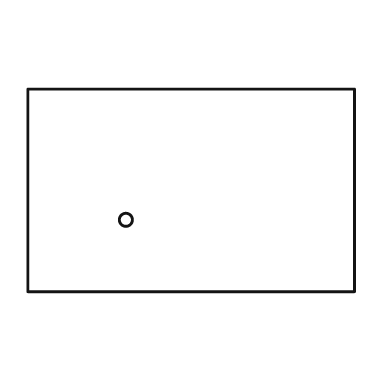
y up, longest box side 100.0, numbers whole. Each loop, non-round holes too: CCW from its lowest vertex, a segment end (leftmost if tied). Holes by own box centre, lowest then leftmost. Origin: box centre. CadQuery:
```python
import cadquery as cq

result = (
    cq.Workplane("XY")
    .moveTo(-50.0, -31.0)
    .lineTo(50.0, -31.0)
    .lineTo(50.0, 31.0)
    .lineTo(-50.0, 31.0)
    .close()
    .moveTo(-20.0, -9.0)
    .circle(2.0)
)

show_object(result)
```